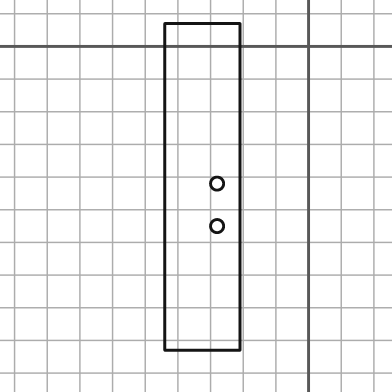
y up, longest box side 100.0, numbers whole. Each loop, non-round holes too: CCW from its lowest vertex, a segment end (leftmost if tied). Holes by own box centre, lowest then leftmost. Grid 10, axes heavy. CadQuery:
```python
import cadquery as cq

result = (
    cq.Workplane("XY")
    .moveTo(-44.0, -93.0)
    .lineTo(-21.0, -93.0)
    .lineTo(-21.0, 7.0)
    .lineTo(-44.0, 7.0)
    .close()
    .moveTo(-28.0, -55.0)
    .circle(2.0)
    .moveTo(-28.0, -42.0)
    .circle(2.0)
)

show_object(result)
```